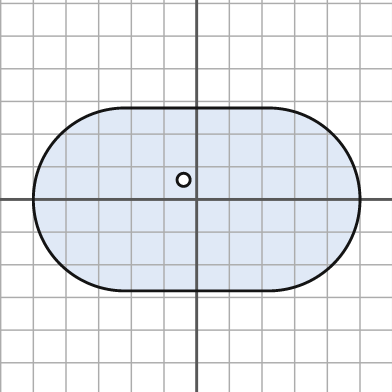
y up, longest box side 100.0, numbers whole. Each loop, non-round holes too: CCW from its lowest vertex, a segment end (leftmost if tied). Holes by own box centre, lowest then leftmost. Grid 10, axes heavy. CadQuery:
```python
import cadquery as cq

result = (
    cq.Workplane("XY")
    .moveTo(-22.0, -28.0)
    .lineTo(22.0, -28.0)
    .threePointArc((50.0, 0.0), (22.0, 28.0))
    .lineTo(-22.0, 28.0)
    .threePointArc((-50.0, 0.0), (-22.0, -28.0))
    .close()
    .moveTo(-4.0, 6.0)
    .circle(2.0)
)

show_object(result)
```